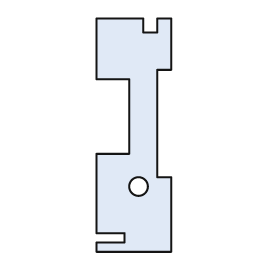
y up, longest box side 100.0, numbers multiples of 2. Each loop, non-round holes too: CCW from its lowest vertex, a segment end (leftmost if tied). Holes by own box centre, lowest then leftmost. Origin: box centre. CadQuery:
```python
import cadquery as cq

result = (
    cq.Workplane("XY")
    .moveTo(-16.0, -50.0)
    .lineTo(16.0, -50.0)
    .lineTo(16.0, -18.0)
    .lineTo(10.0, -18.0)
    .lineTo(10.0, 28.0)
    .lineTo(16.0, 28.0)
    .lineTo(16.0, 50.0)
    .lineTo(10.0, 50.0)
    .lineTo(10.0, 44.0)
    .lineTo(4.0, 44.0)
    .lineTo(4.0, 50.0)
    .lineTo(-16.0, 50.0)
    .lineTo(-16.0, 24.0)
    .lineTo(-2.0, 24.0)
    .lineTo(-2.0, -8.0)
    .lineTo(-16.0, -8.0)
    .lineTo(-16.0, -42.0)
    .lineTo(-4.0, -42.0)
    .lineTo(-4.0, -46.0)
    .lineTo(-16.0, -46.0)
    .close()
    .moveTo(2.0, -22.0)
    .circle(4.0)
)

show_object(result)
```